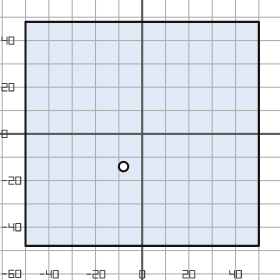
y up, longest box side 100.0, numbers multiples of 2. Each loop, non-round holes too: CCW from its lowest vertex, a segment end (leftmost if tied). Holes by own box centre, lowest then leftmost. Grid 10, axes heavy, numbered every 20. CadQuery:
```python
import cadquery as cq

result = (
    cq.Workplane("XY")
    .moveTo(-50.0, -48.0)
    .lineTo(50.0, -48.0)
    .lineTo(50.0, 48.0)
    .lineTo(-50.0, 48.0)
    .close()
    .moveTo(-8.0, -14.0)
    .circle(2.0)
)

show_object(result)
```